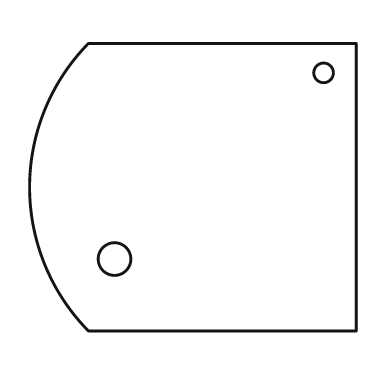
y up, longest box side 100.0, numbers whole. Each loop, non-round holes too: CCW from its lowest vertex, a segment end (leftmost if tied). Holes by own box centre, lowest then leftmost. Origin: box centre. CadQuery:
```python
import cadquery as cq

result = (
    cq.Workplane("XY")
    .moveTo(-32.0, -44.0)
    .lineTo(50.0, -44.0)
    .lineTo(50.0, 44.0)
    .lineTo(-32.0, 44.0)
    .threePointArc((-50.0, 0.0), (-32.0, -44.0))
    .close()
    .moveTo(-24.0, -22.0)
    .circle(5.0)
    .moveTo(40.0, 35.0)
    .circle(3.0)
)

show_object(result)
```